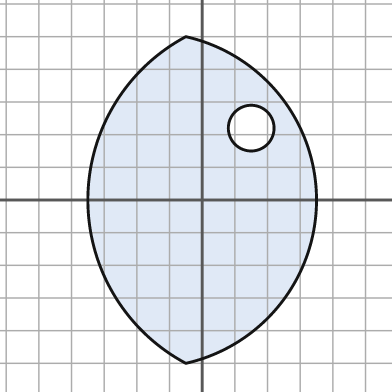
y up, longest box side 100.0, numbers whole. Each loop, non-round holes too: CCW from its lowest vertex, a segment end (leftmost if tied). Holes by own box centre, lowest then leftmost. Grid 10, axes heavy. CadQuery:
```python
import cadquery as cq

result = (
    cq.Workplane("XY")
    .moveTo(-5.0, -50.0)
    .threePointArc((35.0, 0.0), (-5.0, 50.0))
    .threePointArc((-35.0, 0.0), (-5.0, -50.0))
    .close()
    .moveTo(15.0, 22.0)
    .circle(7.0)
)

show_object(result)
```